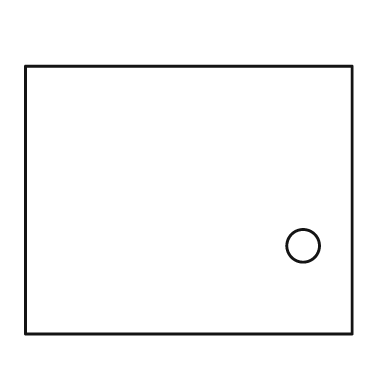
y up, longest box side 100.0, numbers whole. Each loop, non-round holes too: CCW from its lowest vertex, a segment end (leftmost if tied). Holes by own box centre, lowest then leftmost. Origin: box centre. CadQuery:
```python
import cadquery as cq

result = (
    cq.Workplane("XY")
    .moveTo(-50.0, -41.0)
    .lineTo(50.0, -41.0)
    .lineTo(50.0, 41.0)
    .lineTo(-50.0, 41.0)
    .close()
    .moveTo(35.0, -14.0)
    .circle(5.0)
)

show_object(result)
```